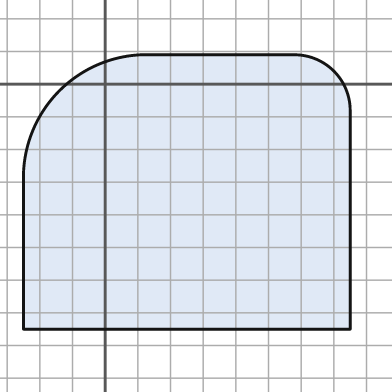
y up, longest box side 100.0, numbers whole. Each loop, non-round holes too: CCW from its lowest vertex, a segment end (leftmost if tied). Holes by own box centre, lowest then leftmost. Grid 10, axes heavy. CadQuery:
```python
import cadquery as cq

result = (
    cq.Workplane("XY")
    .moveTo(-25.0, -75.0)
    .lineTo(75.0, -75.0)
    .lineTo(75.0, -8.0)
    .threePointArc((70.0, 4.0), (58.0, 9.0))
    .lineTo(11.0, 9.0)
    .threePointArc((-14.0, -2.0), (-25.0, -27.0))
    .close()
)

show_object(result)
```